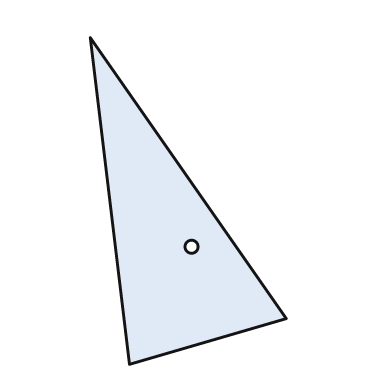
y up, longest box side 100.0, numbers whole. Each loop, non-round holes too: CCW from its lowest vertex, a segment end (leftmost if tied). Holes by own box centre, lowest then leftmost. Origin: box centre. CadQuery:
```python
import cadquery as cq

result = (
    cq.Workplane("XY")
    .moveTo(-18.0, -50.0)
    .lineTo(30.0, -36.0)
    .lineTo(-30.0, 50.0)
    .close()
    .moveTo(1.0, -14.0)
    .circle(2.0)
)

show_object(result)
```